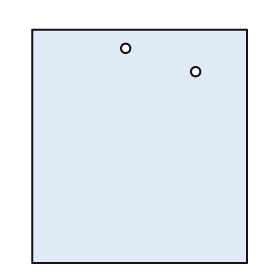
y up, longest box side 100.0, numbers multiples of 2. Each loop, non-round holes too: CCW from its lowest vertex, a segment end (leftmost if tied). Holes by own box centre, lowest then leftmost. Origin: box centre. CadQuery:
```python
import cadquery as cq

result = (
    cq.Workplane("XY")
    .moveTo(-46.0, -50.0)
    .lineTo(46.0, -50.0)
    .lineTo(46.0, 50.0)
    .lineTo(-46.0, 50.0)
    .close()
    .moveTo(24.0, 32.0)
    .circle(2.0)
    .moveTo(-6.0, 42.0)
    .circle(2.0)
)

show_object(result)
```